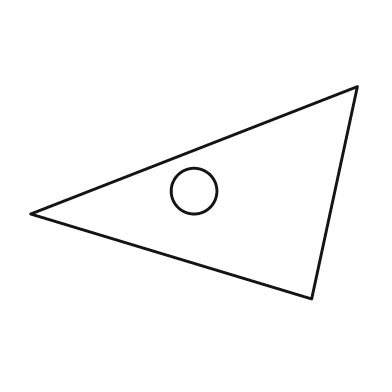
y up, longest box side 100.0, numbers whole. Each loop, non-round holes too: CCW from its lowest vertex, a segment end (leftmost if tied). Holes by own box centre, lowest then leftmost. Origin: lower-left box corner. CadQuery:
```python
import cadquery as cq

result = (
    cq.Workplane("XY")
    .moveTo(86.0, 0.0)
    .lineTo(100.0, 65.0)
    .lineTo(0.0, 26.0)
    .close()
    .moveTo(50.0, 33.0)
    .circle(7.0)
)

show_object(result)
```